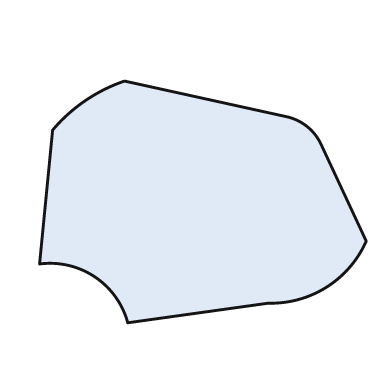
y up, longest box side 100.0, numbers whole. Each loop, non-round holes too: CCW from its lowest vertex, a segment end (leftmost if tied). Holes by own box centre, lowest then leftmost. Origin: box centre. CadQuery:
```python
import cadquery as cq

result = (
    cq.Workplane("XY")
    .moveTo(-23.0, -37.0)
    .lineTo(20.0, -31.0)
    .threePointArc((38.0, -26.0), (50.0, -12.0))
    .lineTo(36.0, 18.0)
    .threePointArc((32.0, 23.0), (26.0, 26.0))
    .lineTo(-24.0, 37.0)
    .threePointArc((-36.0, 31.0), (-46.0, 22.0))
    .lineTo(-50.0, -19.0)
    .threePointArc((-33.0, -23.0), (-23.0, -37.0))
    .close()
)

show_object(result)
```